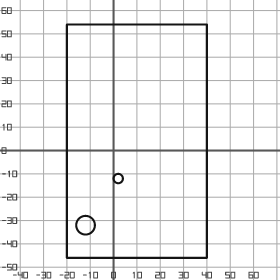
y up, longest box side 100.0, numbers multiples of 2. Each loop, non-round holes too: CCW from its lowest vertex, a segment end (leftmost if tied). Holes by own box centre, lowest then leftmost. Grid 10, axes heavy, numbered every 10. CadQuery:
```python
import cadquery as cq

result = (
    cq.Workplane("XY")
    .moveTo(-20.0, -46.0)
    .lineTo(40.0, -46.0)
    .lineTo(40.0, 54.0)
    .lineTo(-20.0, 54.0)
    .close()
    .moveTo(-12.0, -32.0)
    .circle(4.0)
    .moveTo(2.0, -12.0)
    .circle(2.0)
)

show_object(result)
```